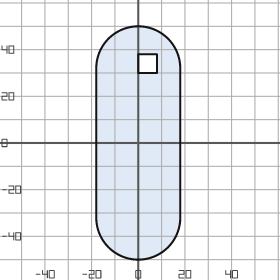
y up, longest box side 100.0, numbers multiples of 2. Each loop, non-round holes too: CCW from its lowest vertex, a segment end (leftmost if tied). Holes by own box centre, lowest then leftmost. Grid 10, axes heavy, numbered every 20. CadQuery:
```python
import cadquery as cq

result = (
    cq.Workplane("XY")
    .moveTo(-18.0, -32.0)
    .threePointArc((0.0, -50.0), (18.0, -32.0))
    .lineTo(18.0, 32.0)
    .threePointArc((0.0, 50.0), (-18.0, 32.0))
    .close()
    .moveTo(0.0, 30.0)
    .lineTo(8.0, 30.0)
    .lineTo(8.0, 38.0)
    .lineTo(0.0, 38.0)
    .close()
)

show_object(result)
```